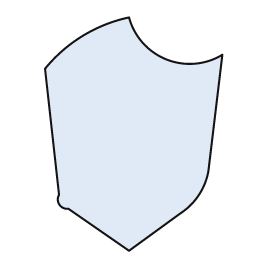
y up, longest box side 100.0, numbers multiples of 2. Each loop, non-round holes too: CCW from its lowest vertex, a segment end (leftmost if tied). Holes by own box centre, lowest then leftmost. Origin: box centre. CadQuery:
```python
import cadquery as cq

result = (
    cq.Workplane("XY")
    .moveTo(-2.0, -50.0)
    .lineTo(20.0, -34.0)
    .threePointArc((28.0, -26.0), (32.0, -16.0))
    .lineTo(38.0, 34.0)
    .threePointArc((14.0, 32.0), (-2.0, 50.0))
    .threePointArc((-22.0, 42.0), (-38.0, 28.0))
    .lineTo(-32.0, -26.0)
    .threePointArc((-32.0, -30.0), (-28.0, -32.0))
    .close()
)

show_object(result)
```